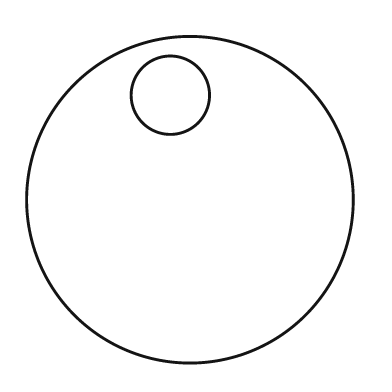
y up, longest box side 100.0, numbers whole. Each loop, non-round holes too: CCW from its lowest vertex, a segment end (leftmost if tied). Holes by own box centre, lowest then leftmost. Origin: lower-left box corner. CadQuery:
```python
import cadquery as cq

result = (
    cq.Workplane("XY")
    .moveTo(50.0, 50.0)
    .circle(50.0)
    .moveTo(44.0, 82.0)
    .circle(12.0)
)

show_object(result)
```